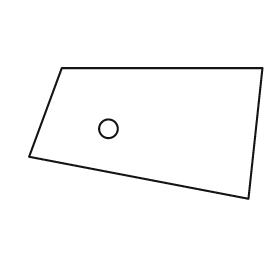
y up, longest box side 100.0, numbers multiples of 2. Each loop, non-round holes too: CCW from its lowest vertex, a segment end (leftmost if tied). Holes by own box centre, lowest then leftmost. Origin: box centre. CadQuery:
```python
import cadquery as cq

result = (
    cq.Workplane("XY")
    .moveTo(44.0, -28.0)
    .lineTo(50.0, 28.0)
    .lineTo(-36.0, 28.0)
    .lineTo(-50.0, -10.0)
    .close()
    .moveTo(-16.0, 2.0)
    .circle(4.0)
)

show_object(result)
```